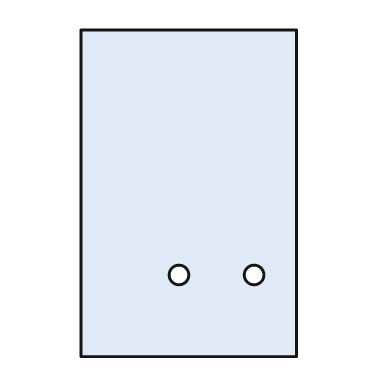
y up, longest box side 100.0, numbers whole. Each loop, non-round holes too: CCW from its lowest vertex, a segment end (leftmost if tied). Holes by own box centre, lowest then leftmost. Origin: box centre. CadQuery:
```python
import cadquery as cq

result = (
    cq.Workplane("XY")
    .moveTo(-33.0, -50.0)
    .lineTo(33.0, -50.0)
    .lineTo(33.0, 50.0)
    .lineTo(-33.0, 50.0)
    .close()
    .moveTo(-3.0, -25.0)
    .circle(3.0)
    .moveTo(20.0, -25.0)
    .circle(3.0)
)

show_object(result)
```